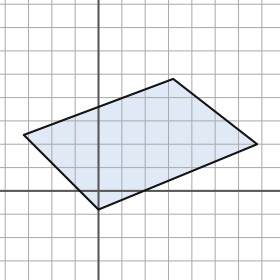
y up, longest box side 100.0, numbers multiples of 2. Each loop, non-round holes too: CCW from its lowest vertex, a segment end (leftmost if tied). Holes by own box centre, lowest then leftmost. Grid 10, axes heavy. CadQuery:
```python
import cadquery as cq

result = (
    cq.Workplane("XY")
    .moveTo(0.0, -8.0)
    .lineTo(68.0, 20.0)
    .lineTo(32.0, 48.0)
    .lineTo(-32.0, 24.0)
    .close()
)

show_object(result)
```